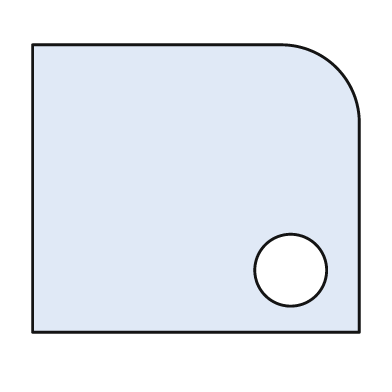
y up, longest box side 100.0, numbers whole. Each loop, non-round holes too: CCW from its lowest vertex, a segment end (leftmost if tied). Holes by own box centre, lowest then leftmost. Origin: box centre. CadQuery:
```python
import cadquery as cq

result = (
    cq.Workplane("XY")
    .moveTo(-50.0, -44.0)
    .lineTo(50.0, -44.0)
    .lineTo(50.0, 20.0)
    .threePointArc((43.0, 37.0), (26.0, 44.0))
    .lineTo(-50.0, 44.0)
    .close()
    .moveTo(29.0, -25.0)
    .circle(11.0)
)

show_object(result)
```